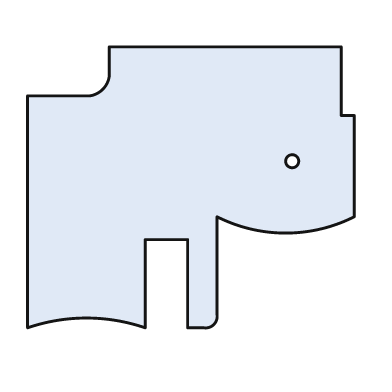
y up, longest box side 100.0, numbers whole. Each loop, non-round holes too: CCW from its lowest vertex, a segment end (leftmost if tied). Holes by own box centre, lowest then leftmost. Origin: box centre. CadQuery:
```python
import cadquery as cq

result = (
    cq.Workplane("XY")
    .moveTo(-50.0, -43.0)
    .threePointArc((-32.0, -40.0), (-14.0, -43.0))
    .lineTo(-14.0, -16.0)
    .lineTo(-1.0, -16.0)
    .lineTo(-1.0, -43.0)
    .lineTo(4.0, -43.0)
    .threePointArc((7.0, -42.0), (8.0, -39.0))
    .lineTo(8.0, -9.0)
    .threePointArc((29.0, -14.0), (50.0, -9.0))
    .lineTo(50.0, 22.0)
    .lineTo(46.0, 22.0)
    .lineTo(46.0, 43.0)
    .lineTo(-25.0, 43.0)
    .lineTo(-25.0, 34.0)
    .threePointArc((-27.0, 30.0), (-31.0, 28.0))
    .lineTo(-50.0, 28.0)
    .close()
    .moveTo(31.0, 8.0)
    .circle(2.0)
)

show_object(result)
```